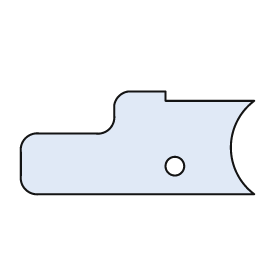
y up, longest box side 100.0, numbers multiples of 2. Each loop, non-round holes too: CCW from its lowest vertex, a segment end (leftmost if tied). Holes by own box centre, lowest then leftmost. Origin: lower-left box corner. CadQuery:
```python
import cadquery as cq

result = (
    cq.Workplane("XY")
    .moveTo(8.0, 0.0)
    .lineTo(100.0, 0.0)
    .threePointArc((90.0, 20.0), (100.0, 40.0))
    .lineTo(62.0, 40.0)
    .lineTo(62.0, 44.0)
    .lineTo(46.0, 44.0)
    .threePointArc((42.0, 42.0), (40.0, 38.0))
    .lineTo(40.0, 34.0)
    .threePointArc((38.0, 28.0), (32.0, 26.0))
    .lineTo(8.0, 26.0)
    .threePointArc((2.0, 24.0), (0.0, 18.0))
    .lineTo(0.0, 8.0)
    .threePointArc((2.0, 2.0), (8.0, 0.0))
    .close()
    .moveTo(66.0, 12.0)
    .circle(4.0)
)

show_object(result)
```